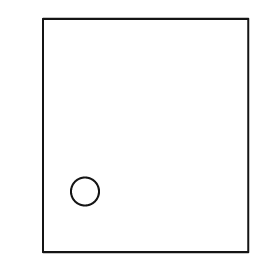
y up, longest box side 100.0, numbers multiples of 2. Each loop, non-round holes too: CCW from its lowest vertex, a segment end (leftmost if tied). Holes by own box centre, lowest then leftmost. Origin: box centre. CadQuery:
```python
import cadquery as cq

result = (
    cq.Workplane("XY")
    .moveTo(-44.0, -50.0)
    .lineTo(44.0, -50.0)
    .lineTo(44.0, 50.0)
    .lineTo(-44.0, 50.0)
    .close()
    .moveTo(-26.0, -24.0)
    .circle(6.0)
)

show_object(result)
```